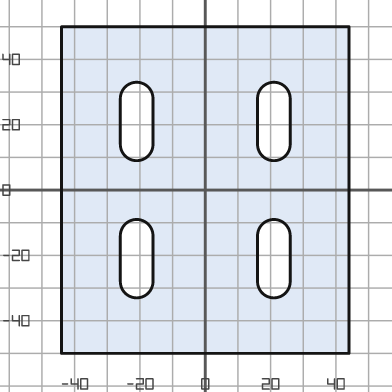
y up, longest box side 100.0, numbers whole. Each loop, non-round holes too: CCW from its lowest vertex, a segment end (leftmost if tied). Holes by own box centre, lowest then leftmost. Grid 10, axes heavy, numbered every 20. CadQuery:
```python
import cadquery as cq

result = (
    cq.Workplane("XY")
    .moveTo(-44.0, -50.0)
    .lineTo(44.0, -50.0)
    .lineTo(44.0, 50.0)
    .lineTo(-44.0, 50.0)
    .close()
    .moveTo(-26.0, -28.0)
    .threePointArc((-21.0, -33.0), (-16.0, -28.0))
    .lineTo(-16.0, -14.0)
    .threePointArc((-21.0, -9.0), (-26.0, -14.0))
    .close()
    .moveTo(16.0, -28.0)
    .threePointArc((21.0, -33.0), (26.0, -28.0))
    .lineTo(26.0, -14.0)
    .threePointArc((21.0, -9.0), (16.0, -14.0))
    .close()
    .moveTo(-26.0, 14.0)
    .threePointArc((-21.0, 9.0), (-16.0, 14.0))
    .lineTo(-16.0, 28.0)
    .threePointArc((-21.0, 33.0), (-26.0, 28.0))
    .close()
    .moveTo(16.0, 14.0)
    .threePointArc((21.0, 9.0), (26.0, 14.0))
    .lineTo(26.0, 28.0)
    .threePointArc((21.0, 33.0), (16.0, 28.0))
    .close()
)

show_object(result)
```